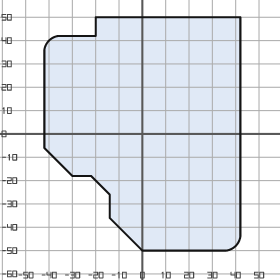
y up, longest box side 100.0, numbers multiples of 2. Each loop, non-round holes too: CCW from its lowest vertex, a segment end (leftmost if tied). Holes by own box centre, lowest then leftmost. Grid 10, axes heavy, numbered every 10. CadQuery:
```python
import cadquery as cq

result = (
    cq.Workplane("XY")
    .moveTo(0.0, -50.0)
    .lineTo(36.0, -50.0)
    .threePointArc((40.0, -48.0), (42.0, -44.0))
    .lineTo(42.0, 50.0)
    .lineTo(-20.0, 50.0)
    .lineTo(-20.0, 42.0)
    .lineTo(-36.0, 42.0)
    .threePointArc((-40.0, 40.0), (-42.0, 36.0))
    .lineTo(-42.0, -6.0)
    .lineTo(-30.0, -18.0)
    .lineTo(-22.0, -18.0)
    .lineTo(-14.0, -26.0)
    .lineTo(-14.0, -36.0)
    .close()
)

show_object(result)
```